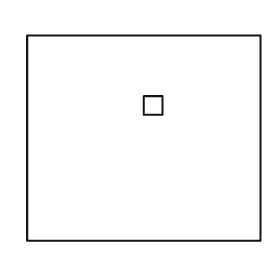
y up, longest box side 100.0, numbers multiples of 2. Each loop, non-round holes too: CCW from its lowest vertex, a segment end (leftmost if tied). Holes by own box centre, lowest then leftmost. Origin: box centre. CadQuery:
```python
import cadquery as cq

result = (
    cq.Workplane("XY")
    .moveTo(-50.0, -44.0)
    .lineTo(50.0, -44.0)
    .lineTo(50.0, 44.0)
    .lineTo(-50.0, 44.0)
    .close()
    .moveTo(0.0, 10.0)
    .lineTo(8.0, 10.0)
    .lineTo(8.0, 18.0)
    .lineTo(0.0, 18.0)
    .close()
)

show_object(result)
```